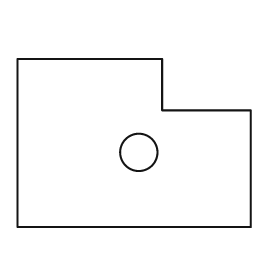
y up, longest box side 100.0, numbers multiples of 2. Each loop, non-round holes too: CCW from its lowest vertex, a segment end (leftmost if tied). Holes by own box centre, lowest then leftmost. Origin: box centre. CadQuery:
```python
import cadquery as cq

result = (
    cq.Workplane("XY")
    .moveTo(-50.0, -36.0)
    .lineTo(50.0, -36.0)
    .lineTo(50.0, 14.0)
    .lineTo(12.0, 14.0)
    .lineTo(12.0, 36.0)
    .lineTo(-50.0, 36.0)
    .close()
    .moveTo(2.0, -4.0)
    .circle(8.0)
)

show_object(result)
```